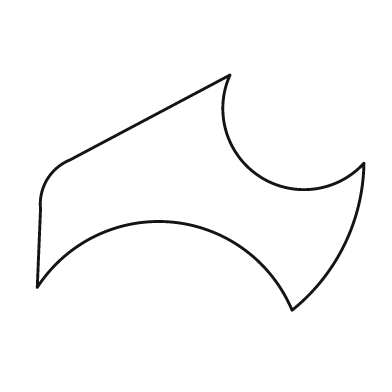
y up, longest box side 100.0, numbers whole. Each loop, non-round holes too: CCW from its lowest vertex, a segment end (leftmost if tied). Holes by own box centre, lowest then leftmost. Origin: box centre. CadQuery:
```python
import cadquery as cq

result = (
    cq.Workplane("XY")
    .moveTo(28.0, -36.0)
    .threePointArc((44.0, -16.0), (50.0, 9.0))
    .threePointArc((18.0, 5.0), (9.0, 36.0))
    .lineTo(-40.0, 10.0)
    .threePointArc((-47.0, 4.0), (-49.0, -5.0))
    .lineTo(-50.0, -29.0)
    .threePointArc((-9.0, -9.0), (28.0, -36.0))
    .close()
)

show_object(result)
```